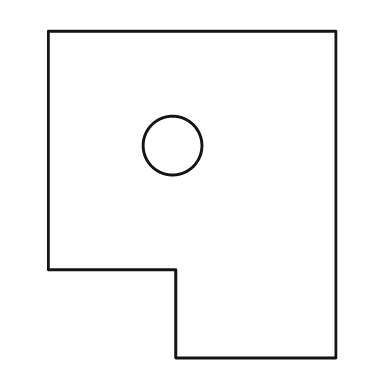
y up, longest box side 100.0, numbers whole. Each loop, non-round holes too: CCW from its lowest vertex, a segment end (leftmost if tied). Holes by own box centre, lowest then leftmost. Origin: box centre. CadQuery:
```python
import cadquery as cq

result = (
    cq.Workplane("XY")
    .moveTo(-5.0, -50.0)
    .lineTo(44.0, -50.0)
    .lineTo(44.0, 50.0)
    .lineTo(-44.0, 50.0)
    .lineTo(-44.0, -23.0)
    .lineTo(-5.0, -23.0)
    .close()
    .moveTo(-6.0, 15.0)
    .circle(9.0)
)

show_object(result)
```